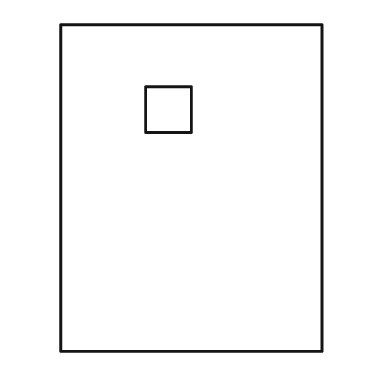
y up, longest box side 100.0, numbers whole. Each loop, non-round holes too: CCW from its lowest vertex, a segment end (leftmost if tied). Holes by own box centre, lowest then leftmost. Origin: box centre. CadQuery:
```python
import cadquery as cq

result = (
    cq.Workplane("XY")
    .moveTo(-40.0, -50.0)
    .lineTo(40.0, -50.0)
    .lineTo(40.0, 50.0)
    .lineTo(-40.0, 50.0)
    .close()
    .moveTo(-14.0, 17.0)
    .lineTo(0.0, 17.0)
    .lineTo(0.0, 31.0)
    .lineTo(-14.0, 31.0)
    .close()
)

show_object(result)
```